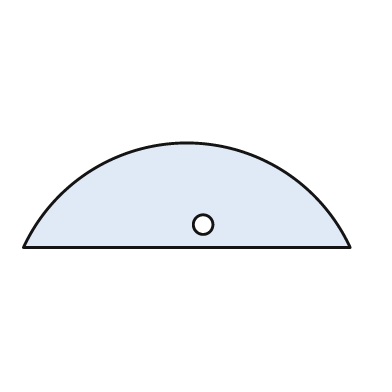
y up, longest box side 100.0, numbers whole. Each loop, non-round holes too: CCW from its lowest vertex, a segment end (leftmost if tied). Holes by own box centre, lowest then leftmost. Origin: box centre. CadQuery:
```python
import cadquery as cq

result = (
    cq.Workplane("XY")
    .moveTo(-50.0, -16.0)
    .lineTo(50.0, -16.0)
    .threePointArc((0.0, 16.0), (-50.0, -16.0))
    .close()
    .moveTo(5.0, -9.0)
    .circle(3.0)
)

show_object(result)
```